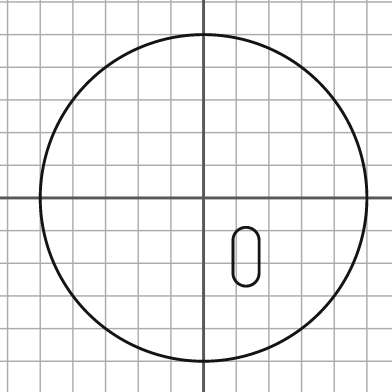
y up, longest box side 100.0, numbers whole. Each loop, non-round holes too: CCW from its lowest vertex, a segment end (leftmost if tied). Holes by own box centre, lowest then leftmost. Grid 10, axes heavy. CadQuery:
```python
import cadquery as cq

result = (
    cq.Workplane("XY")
    .moveTo(0.0, 0.0)
    .circle(50.0)
    .moveTo(9.0, -23.0)
    .threePointArc((13.0, -27.0), (17.0, -23.0))
    .lineTo(17.0, -13.0)
    .threePointArc((13.0, -9.0), (9.0, -13.0))
    .close()
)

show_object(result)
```